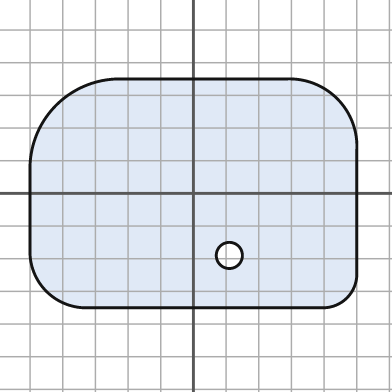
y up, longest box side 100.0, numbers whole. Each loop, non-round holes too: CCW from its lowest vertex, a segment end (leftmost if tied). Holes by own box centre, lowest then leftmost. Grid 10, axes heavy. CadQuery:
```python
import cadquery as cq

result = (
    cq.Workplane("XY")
    .moveTo(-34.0, -35.0)
    .lineTo(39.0, -35.0)
    .threePointArc((47.0, -32.0), (50.0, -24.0))
    .lineTo(50.0, 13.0)
    .threePointArc((44.0, 29.0), (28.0, 35.0))
    .lineTo(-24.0, 35.0)
    .threePointArc((-42.0, 27.0), (-50.0, 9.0))
    .lineTo(-50.0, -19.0)
    .threePointArc((-45.0, -30.0), (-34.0, -35.0))
    .close()
    .moveTo(11.0, -19.0)
    .circle(4.0)
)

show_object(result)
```